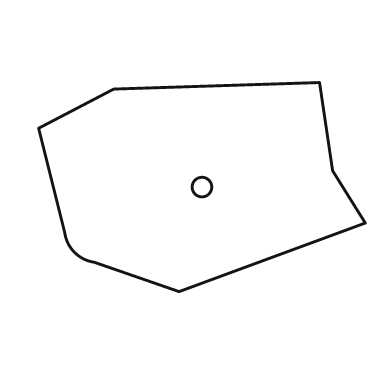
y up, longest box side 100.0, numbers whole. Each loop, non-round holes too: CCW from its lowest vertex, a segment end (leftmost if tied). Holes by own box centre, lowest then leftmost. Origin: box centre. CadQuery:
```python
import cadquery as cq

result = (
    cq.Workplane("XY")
    .moveTo(-7.0, -32.0)
    .lineTo(50.0, -11.0)
    .lineTo(40.0, 5.0)
    .lineTo(36.0, 32.0)
    .lineTo(-27.0, 30.0)
    .lineTo(-50.0, 18.0)
    .lineTo(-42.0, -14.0)
    .threePointArc((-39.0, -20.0), (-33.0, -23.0))
    .close()
    .moveTo(0.0, 0.0)
    .circle(3.0)
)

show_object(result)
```